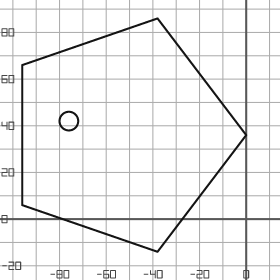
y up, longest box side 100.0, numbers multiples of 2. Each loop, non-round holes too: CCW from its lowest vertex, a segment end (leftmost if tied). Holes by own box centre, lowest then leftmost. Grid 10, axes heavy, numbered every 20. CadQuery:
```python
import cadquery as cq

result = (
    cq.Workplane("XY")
    .moveTo(-38.0, -14.0)
    .lineTo(0.0, 36.0)
    .lineTo(-38.0, 86.0)
    .lineTo(-96.0, 66.0)
    .lineTo(-96.0, 6.0)
    .close()
    .moveTo(-76.0, 42.0)
    .circle(4.0)
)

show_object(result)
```